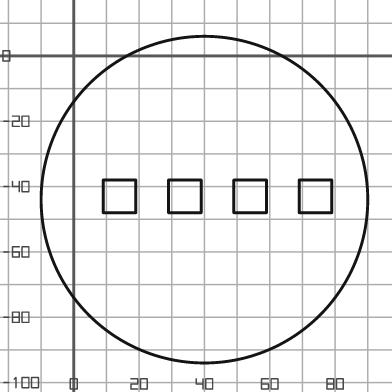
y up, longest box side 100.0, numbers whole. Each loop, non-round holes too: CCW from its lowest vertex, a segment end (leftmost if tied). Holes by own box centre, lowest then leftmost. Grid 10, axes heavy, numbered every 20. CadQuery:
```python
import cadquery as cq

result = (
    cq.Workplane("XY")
    .moveTo(40.0, -44.0)
    .circle(50.0)
    .moveTo(9.0, -48.0)
    .lineTo(19.0, -48.0)
    .lineTo(19.0, -38.0)
    .lineTo(9.0, -38.0)
    .close()
    .moveTo(29.0, -48.0)
    .lineTo(39.0, -48.0)
    .lineTo(39.0, -38.0)
    .lineTo(29.0, -38.0)
    .close()
    .moveTo(49.0, -48.0)
    .lineTo(59.0, -48.0)
    .lineTo(59.0, -38.0)
    .lineTo(49.0, -38.0)
    .close()
    .moveTo(69.0, -48.0)
    .lineTo(79.0, -48.0)
    .lineTo(79.0, -38.0)
    .lineTo(69.0, -38.0)
    .close()
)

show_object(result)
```